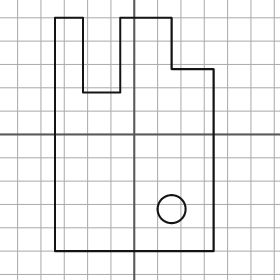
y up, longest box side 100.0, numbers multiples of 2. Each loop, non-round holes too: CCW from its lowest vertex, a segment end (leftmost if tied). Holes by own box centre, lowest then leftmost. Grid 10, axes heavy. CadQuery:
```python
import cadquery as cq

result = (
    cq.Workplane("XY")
    .moveTo(-34.0, -50.0)
    .lineTo(34.0, -50.0)
    .lineTo(34.0, 28.0)
    .lineTo(16.0, 28.0)
    .lineTo(16.0, 50.0)
    .lineTo(-6.0, 50.0)
    .lineTo(-6.0, 18.0)
    .lineTo(-22.0, 18.0)
    .lineTo(-22.0, 50.0)
    .lineTo(-34.0, 50.0)
    .close()
    .moveTo(16.0, -32.0)
    .circle(6.0)
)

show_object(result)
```